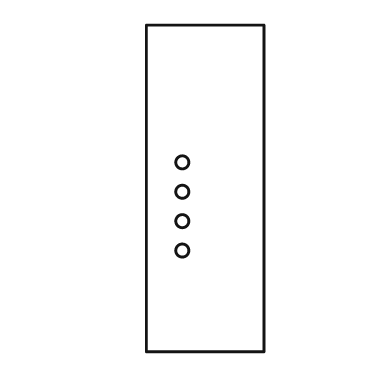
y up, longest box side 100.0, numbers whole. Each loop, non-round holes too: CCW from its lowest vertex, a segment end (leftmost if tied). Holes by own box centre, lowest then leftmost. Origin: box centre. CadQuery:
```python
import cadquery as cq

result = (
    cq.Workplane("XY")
    .moveTo(-18.0, -50.0)
    .lineTo(18.0, -50.0)
    .lineTo(18.0, 50.0)
    .lineTo(-18.0, 50.0)
    .close()
    .moveTo(-7.0, -19.0)
    .circle(2.0)
    .moveTo(-7.0, -10.0)
    .circle(2.0)
    .moveTo(-7.0, -1.0)
    .circle(2.0)
    .moveTo(-7.0, 8.0)
    .circle(2.0)
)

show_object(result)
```